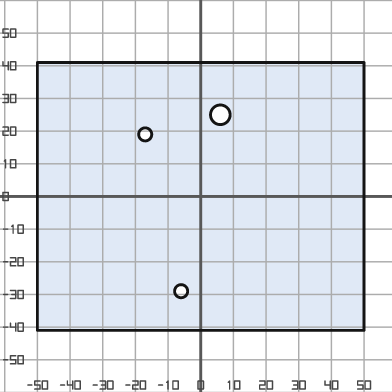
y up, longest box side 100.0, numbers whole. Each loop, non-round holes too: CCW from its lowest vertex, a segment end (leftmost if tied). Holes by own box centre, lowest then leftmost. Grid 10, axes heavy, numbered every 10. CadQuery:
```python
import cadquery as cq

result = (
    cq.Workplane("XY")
    .moveTo(-50.0, -41.0)
    .lineTo(50.0, -41.0)
    .lineTo(50.0, 41.0)
    .lineTo(-50.0, 41.0)
    .close()
    .moveTo(-6.0, -29.0)
    .circle(2.0)
    .moveTo(-17.0, 19.0)
    .circle(2.0)
    .moveTo(6.0, 25.0)
    .circle(3.0)
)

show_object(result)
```